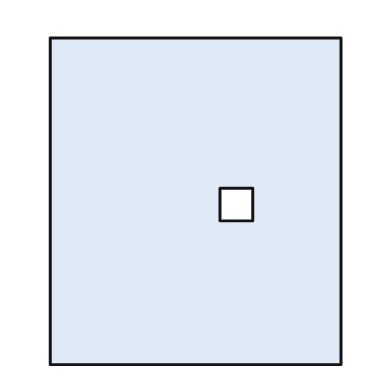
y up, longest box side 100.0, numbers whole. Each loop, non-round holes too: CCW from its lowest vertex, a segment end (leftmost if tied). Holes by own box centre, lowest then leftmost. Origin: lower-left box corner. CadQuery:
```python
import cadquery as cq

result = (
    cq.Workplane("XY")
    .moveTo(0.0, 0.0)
    .lineTo(89.0, 0.0)
    .lineTo(89.0, 100.0)
    .lineTo(0.0, 100.0)
    .close()
    .moveTo(52.0, 44.0)
    .lineTo(62.0, 44.0)
    .lineTo(62.0, 54.0)
    .lineTo(52.0, 54.0)
    .close()
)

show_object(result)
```